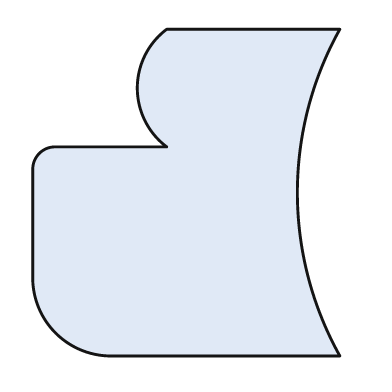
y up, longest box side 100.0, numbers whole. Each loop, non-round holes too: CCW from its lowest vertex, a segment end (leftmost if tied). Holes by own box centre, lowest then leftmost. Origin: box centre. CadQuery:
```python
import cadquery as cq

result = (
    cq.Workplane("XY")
    .moveTo(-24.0, -50.0)
    .lineTo(47.0, -50.0)
    .threePointArc((34.0, 0.0), (47.0, 50.0))
    .lineTo(-6.0, 50.0)
    .threePointArc((-15.0, 32.0), (-6.0, 14.0))
    .lineTo(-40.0, 14.0)
    .threePointArc((-45.0, 12.0), (-47.0, 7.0))
    .lineTo(-47.0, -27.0)
    .threePointArc((-40.0, -43.0), (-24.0, -50.0))
    .close()
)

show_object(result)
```